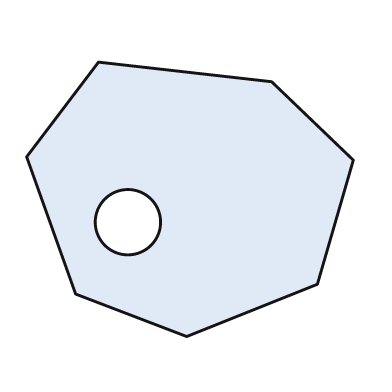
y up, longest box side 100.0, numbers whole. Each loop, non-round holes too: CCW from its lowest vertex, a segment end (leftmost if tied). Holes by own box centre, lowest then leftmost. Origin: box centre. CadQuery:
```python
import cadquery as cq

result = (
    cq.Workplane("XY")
    .moveTo(-1.0, -42.0)
    .lineTo(39.0, -26.0)
    .lineTo(50.0, 12.0)
    .lineTo(25.0, 36.0)
    .lineTo(-28.0, 42.0)
    .lineTo(-50.0, 13.0)
    .lineTo(-35.0, -29.0)
    .close()
    .moveTo(-19.0, -7.0)
    .circle(10.0)
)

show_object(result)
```